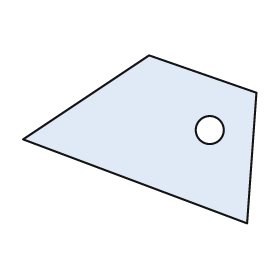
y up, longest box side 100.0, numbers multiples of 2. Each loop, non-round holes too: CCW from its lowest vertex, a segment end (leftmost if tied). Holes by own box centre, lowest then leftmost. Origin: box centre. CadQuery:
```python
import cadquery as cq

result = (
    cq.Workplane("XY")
    .moveTo(46.0, -36.0)
    .lineTo(50.0, 20.0)
    .lineTo(4.0, 36.0)
    .lineTo(-50.0, 0.0)
    .close()
    .moveTo(30.0, 4.0)
    .circle(6.0)
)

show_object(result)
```